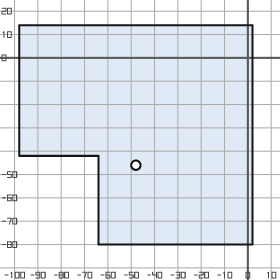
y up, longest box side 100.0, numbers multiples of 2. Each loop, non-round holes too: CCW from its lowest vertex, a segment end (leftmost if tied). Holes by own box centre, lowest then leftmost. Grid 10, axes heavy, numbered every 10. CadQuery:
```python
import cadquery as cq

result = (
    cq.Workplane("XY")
    .moveTo(-64.0, -80.0)
    .lineTo(2.0, -80.0)
    .lineTo(2.0, 14.0)
    .lineTo(-98.0, 14.0)
    .lineTo(-98.0, -42.0)
    .lineTo(-64.0, -42.0)
    .close()
    .moveTo(-48.0, -46.0)
    .circle(2.0)
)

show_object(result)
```